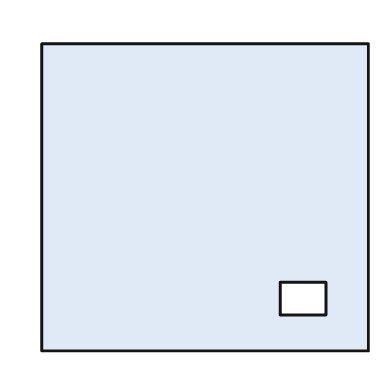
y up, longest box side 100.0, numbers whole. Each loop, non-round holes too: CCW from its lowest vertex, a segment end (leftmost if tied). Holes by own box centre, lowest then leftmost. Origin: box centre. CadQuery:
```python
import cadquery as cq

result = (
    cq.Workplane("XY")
    .moveTo(-50.0, -47.0)
    .lineTo(50.0, -47.0)
    .lineTo(50.0, 47.0)
    .lineTo(-50.0, 47.0)
    .close()
    .moveTo(23.0, -36.0)
    .lineTo(37.0, -36.0)
    .lineTo(37.0, -26.0)
    .lineTo(23.0, -26.0)
    .close()
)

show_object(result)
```